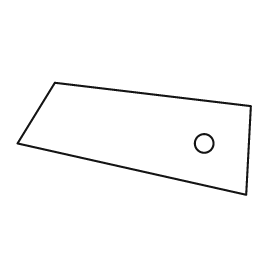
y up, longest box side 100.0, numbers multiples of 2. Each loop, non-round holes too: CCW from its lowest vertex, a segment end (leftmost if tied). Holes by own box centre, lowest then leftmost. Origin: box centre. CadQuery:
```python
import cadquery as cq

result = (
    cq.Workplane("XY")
    .moveTo(48.0, -24.0)
    .lineTo(50.0, 14.0)
    .lineTo(-34.0, 24.0)
    .lineTo(-50.0, -2.0)
    .close()
    .moveTo(30.0, -2.0)
    .circle(4.0)
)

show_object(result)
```